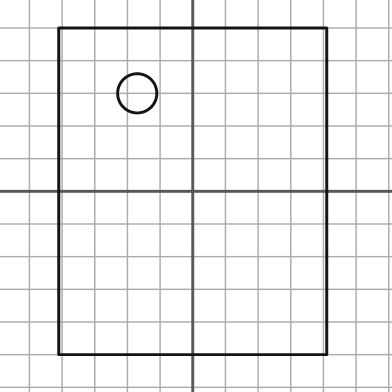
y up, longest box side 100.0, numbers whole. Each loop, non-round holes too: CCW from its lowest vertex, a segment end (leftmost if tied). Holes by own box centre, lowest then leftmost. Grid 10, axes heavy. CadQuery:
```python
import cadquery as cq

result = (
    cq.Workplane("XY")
    .moveTo(-41.0, -50.0)
    .lineTo(41.0, -50.0)
    .lineTo(41.0, 50.0)
    .lineTo(-41.0, 50.0)
    .close()
    .moveTo(-17.0, 30.0)
    .circle(6.0)
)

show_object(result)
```